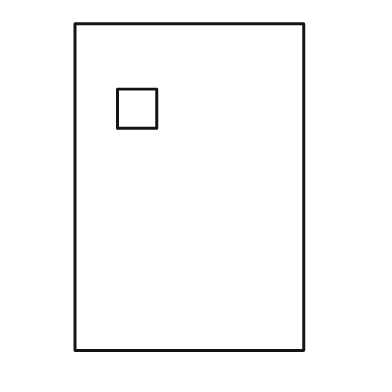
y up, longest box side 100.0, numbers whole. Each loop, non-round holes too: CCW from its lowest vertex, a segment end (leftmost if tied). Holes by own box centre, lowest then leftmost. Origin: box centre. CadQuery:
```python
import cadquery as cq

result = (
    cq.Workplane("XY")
    .moveTo(-35.0, -50.0)
    .lineTo(35.0, -50.0)
    .lineTo(35.0, 50.0)
    .lineTo(-35.0, 50.0)
    .close()
    .moveTo(-22.0, 18.0)
    .lineTo(-10.0, 18.0)
    .lineTo(-10.0, 30.0)
    .lineTo(-22.0, 30.0)
    .close()
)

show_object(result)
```